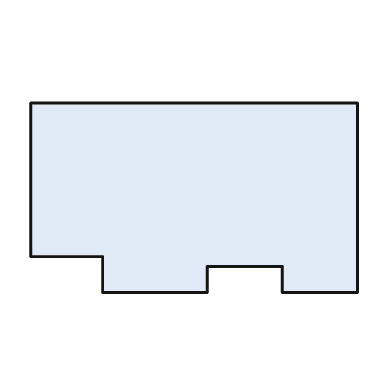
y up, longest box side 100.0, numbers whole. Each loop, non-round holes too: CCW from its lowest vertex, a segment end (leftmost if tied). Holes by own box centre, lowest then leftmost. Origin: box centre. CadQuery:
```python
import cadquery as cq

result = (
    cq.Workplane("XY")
    .moveTo(-28.0, -29.0)
    .lineTo(4.0, -29.0)
    .lineTo(4.0, -21.0)
    .lineTo(27.0, -21.0)
    .lineTo(27.0, -29.0)
    .lineTo(50.0, -29.0)
    .lineTo(50.0, 29.0)
    .lineTo(-50.0, 29.0)
    .lineTo(-50.0, -18.0)
    .lineTo(-28.0, -18.0)
    .close()
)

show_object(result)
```